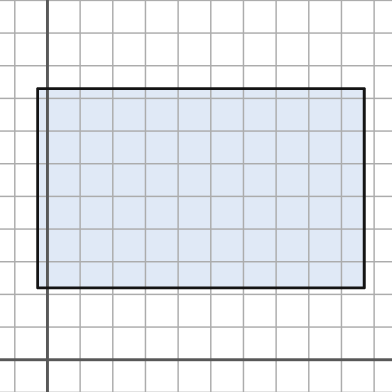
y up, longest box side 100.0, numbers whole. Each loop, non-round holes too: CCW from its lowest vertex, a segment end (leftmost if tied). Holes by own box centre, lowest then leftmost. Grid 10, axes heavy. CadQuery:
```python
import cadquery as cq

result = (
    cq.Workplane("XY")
    .moveTo(-3.0, 22.0)
    .lineTo(97.0, 22.0)
    .lineTo(97.0, 83.0)
    .lineTo(-3.0, 83.0)
    .close()
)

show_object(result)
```